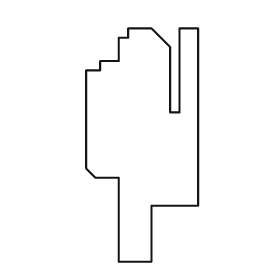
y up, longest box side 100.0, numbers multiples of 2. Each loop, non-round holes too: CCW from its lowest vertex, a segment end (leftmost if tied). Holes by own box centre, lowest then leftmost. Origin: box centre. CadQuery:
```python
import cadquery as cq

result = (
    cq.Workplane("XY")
    .moveTo(-10.0, -50.0)
    .lineTo(4.0, -50.0)
    .lineTo(4.0, -26.0)
    .lineTo(24.0, -26.0)
    .lineTo(24.0, 50.0)
    .lineTo(16.0, 50.0)
    .lineTo(16.0, 14.0)
    .lineTo(12.0, 14.0)
    .lineTo(12.0, 42.0)
    .lineTo(4.0, 50.0)
    .lineTo(-6.0, 50.0)
    .lineTo(-6.0, 46.0)
    .lineTo(-10.0, 46.0)
    .lineTo(-10.0, 36.0)
    .lineTo(-18.0, 36.0)
    .lineTo(-18.0, 32.0)
    .lineTo(-24.0, 32.0)
    .lineTo(-24.0, -10.0)
    .lineTo(-20.0, -14.0)
    .lineTo(-10.0, -14.0)
    .close()
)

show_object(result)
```